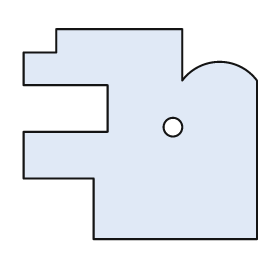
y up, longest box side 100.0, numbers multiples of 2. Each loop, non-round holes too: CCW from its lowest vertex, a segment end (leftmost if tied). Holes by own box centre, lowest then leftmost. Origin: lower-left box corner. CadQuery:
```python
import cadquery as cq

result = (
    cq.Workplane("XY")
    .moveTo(30.0, 0.0)
    .lineTo(100.0, 0.0)
    .lineTo(100.0, 68.0)
    .threePointArc((84.0, 76.0), (68.0, 68.0))
    .lineTo(68.0, 90.0)
    .lineTo(14.0, 90.0)
    .lineTo(14.0, 80.0)
    .lineTo(0.0, 80.0)
    .lineTo(0.0, 66.0)
    .lineTo(36.0, 66.0)
    .lineTo(36.0, 46.0)
    .lineTo(0.0, 46.0)
    .lineTo(0.0, 26.0)
    .lineTo(30.0, 26.0)
    .close()
    .moveTo(64.0, 48.0)
    .circle(4.0)
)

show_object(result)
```